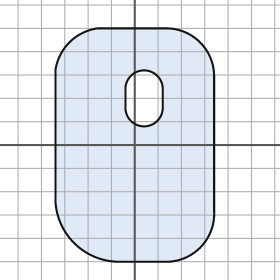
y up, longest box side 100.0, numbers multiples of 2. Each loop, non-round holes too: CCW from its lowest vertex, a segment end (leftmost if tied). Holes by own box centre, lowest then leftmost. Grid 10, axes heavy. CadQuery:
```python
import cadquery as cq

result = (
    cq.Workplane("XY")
    .moveTo(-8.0, -50.0)
    .lineTo(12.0, -50.0)
    .threePointArc((28.0, -44.0), (34.0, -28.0))
    .lineTo(34.0, 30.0)
    .threePointArc((28.0, 44.0), (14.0, 50.0))
    .lineTo(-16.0, 50.0)
    .threePointArc((-28.0, 44.0), (-34.0, 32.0))
    .lineTo(-34.0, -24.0)
    .threePointArc((-26.0, -42.0), (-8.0, -50.0))
    .close()
    .moveTo(-4.0, 16.0)
    .threePointArc((4.0, 8.0), (12.0, 16.0))
    .lineTo(12.0, 24.0)
    .threePointArc((4.0, 32.0), (-4.0, 24.0))
    .close()
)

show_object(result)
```